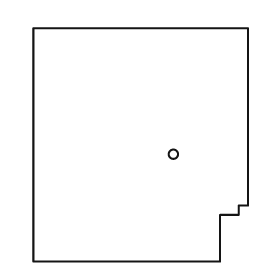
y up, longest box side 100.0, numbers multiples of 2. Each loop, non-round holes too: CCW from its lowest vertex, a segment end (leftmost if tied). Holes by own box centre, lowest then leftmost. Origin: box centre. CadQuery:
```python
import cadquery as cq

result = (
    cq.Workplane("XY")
    .moveTo(-46.0, -50.0)
    .lineTo(34.0, -50.0)
    .lineTo(34.0, -30.0)
    .lineTo(42.0, -30.0)
    .lineTo(42.0, -26.0)
    .lineTo(46.0, -26.0)
    .lineTo(46.0, 50.0)
    .lineTo(-46.0, 50.0)
    .close()
    .moveTo(14.0, -4.0)
    .circle(2.0)
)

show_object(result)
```